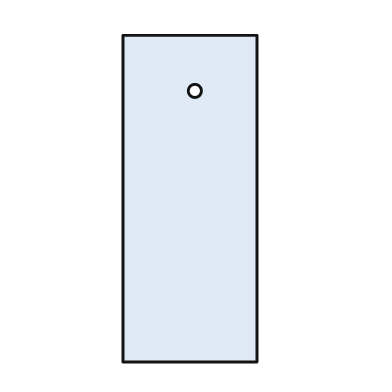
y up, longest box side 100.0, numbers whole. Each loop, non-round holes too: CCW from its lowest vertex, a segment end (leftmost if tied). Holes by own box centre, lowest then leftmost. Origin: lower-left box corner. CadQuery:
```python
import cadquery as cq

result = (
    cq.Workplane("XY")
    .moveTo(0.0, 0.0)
    .lineTo(41.0, 0.0)
    .lineTo(41.0, 100.0)
    .lineTo(0.0, 100.0)
    .close()
    .moveTo(22.0, 83.0)
    .circle(2.0)
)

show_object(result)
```